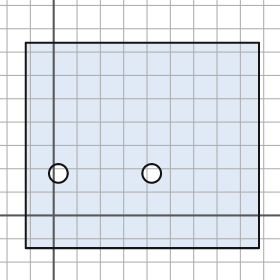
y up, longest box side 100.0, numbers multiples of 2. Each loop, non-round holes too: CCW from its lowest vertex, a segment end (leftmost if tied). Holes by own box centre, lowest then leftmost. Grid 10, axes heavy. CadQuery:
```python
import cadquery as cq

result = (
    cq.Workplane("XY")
    .moveTo(-12.0, -14.0)
    .lineTo(88.0, -14.0)
    .lineTo(88.0, 74.0)
    .lineTo(-12.0, 74.0)
    .close()
    .moveTo(2.0, 18.0)
    .circle(4.0)
    .moveTo(42.0, 18.0)
    .circle(4.0)
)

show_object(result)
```